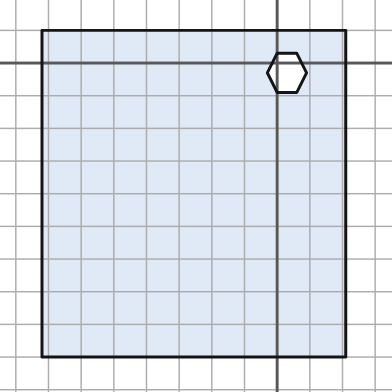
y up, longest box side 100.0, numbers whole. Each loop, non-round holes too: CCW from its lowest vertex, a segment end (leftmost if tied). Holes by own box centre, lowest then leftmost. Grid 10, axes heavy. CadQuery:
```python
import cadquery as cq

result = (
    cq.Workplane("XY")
    .moveTo(-72.0, -90.0)
    .lineTo(21.0, -90.0)
    .lineTo(21.0, 10.0)
    .lineTo(-72.0, 10.0)
    .close()
    .moveTo(0.0, -9.0)
    .lineTo(6.0, -9.0)
    .lineTo(9.0, -3.0)
    .lineTo(6.0, 3.0)
    .lineTo(0.0, 3.0)
    .lineTo(-3.0, -3.0)
    .close()
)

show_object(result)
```